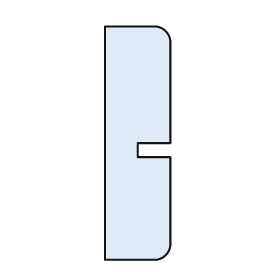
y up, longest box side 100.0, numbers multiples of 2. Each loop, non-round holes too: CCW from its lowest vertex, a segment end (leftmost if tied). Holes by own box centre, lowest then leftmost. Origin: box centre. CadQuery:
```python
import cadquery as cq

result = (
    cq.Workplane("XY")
    .moveTo(-14.0, -50.0)
    .lineTo(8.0, -50.0)
    .threePointArc((12.0, -48.0), (14.0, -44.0))
    .lineTo(14.0, -6.0)
    .lineTo(0.0, -6.0)
    .lineTo(0.0, 0.0)
    .lineTo(14.0, 0.0)
    .lineTo(14.0, 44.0)
    .threePointArc((12.0, 48.0), (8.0, 50.0))
    .lineTo(-14.0, 50.0)
    .close()
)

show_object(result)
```